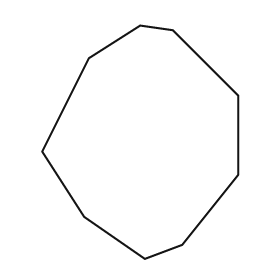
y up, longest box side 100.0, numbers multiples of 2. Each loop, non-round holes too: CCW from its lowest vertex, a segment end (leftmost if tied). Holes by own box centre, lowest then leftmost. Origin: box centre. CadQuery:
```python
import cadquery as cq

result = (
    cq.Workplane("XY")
    .moveTo(2.0, -50.0)
    .lineTo(18.0, -44.0)
    .lineTo(42.0, -14.0)
    .lineTo(42.0, 20.0)
    .lineTo(14.0, 48.0)
    .lineTo(0.0, 50.0)
    .lineTo(-22.0, 36.0)
    .lineTo(-42.0, -4.0)
    .lineTo(-24.0, -32.0)
    .close()
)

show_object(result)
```